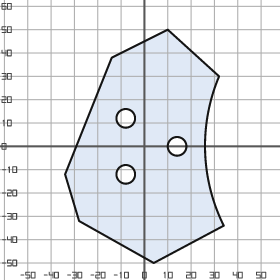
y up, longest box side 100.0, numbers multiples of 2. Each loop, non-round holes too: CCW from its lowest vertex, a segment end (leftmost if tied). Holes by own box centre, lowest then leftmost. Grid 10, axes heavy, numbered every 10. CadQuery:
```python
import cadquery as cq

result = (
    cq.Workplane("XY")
    .moveTo(4.0, -50.0)
    .lineTo(34.0, -34.0)
    .threePointArc((26.0, -2.0), (32.0, 30.0))
    .lineTo(10.0, 50.0)
    .lineTo(-14.0, 38.0)
    .lineTo(-34.0, -12.0)
    .lineTo(-28.0, -32.0)
    .close()
    .moveTo(-8.0, -12.0)
    .circle(4.0)
    .moveTo(14.0, 0.0)
    .circle(4.0)
    .moveTo(-8.0, 12.0)
    .circle(4.0)
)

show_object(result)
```